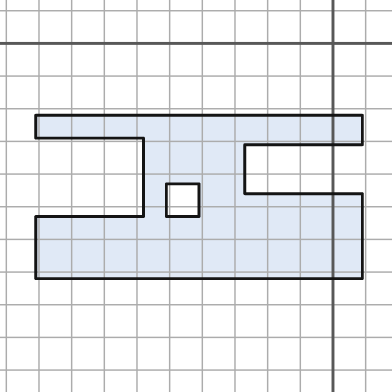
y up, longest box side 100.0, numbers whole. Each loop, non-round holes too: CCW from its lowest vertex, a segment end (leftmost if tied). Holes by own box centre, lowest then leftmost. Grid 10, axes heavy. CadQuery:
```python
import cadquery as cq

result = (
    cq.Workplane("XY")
    .moveTo(-91.0, -72.0)
    .lineTo(9.0, -72.0)
    .lineTo(9.0, -46.0)
    .lineTo(-27.0, -46.0)
    .lineTo(-27.0, -31.0)
    .lineTo(9.0, -31.0)
    .lineTo(9.0, -22.0)
    .lineTo(-91.0, -22.0)
    .lineTo(-91.0, -29.0)
    .lineTo(-58.0, -29.0)
    .lineTo(-58.0, -53.0)
    .lineTo(-91.0, -53.0)
    .close()
    .moveTo(-51.0, -53.0)
    .lineTo(-41.0, -53.0)
    .lineTo(-41.0, -43.0)
    .lineTo(-51.0, -43.0)
    .close()
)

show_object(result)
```